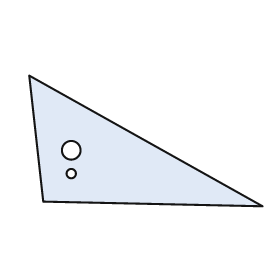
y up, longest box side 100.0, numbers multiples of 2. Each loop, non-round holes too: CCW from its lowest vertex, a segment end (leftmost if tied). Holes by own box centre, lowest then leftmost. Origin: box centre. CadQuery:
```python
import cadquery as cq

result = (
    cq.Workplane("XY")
    .moveTo(50.0, -28.0)
    .lineTo(-50.0, 28.0)
    .lineTo(-44.0, -26.0)
    .close()
    .moveTo(-32.0, -14.0)
    .circle(2.0)
    .moveTo(-32.0, -4.0)
    .circle(4.0)
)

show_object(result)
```